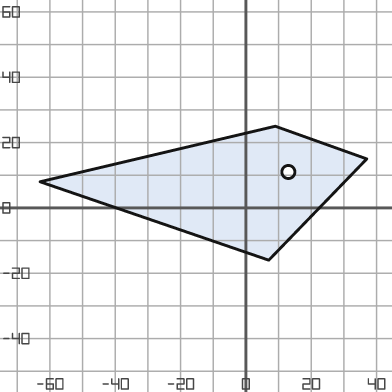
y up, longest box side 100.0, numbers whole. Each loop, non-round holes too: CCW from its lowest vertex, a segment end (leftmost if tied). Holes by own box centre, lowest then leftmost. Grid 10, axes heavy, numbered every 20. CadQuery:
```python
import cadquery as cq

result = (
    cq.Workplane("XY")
    .moveTo(7.0, -16.0)
    .lineTo(37.0, 15.0)
    .lineTo(9.0, 25.0)
    .lineTo(-63.0, 8.0)
    .close()
    .moveTo(13.0, 11.0)
    .circle(2.0)
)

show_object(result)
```